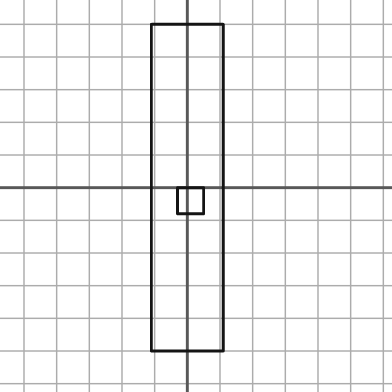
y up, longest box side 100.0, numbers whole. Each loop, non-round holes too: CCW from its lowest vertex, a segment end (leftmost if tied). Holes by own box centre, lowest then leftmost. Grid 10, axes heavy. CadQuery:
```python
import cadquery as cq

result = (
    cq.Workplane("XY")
    .moveTo(-11.0, -50.0)
    .lineTo(11.0, -50.0)
    .lineTo(11.0, 50.0)
    .lineTo(-11.0, 50.0)
    .close()
    .moveTo(-3.0, -8.0)
    .lineTo(5.0, -8.0)
    .lineTo(5.0, 0.0)
    .lineTo(-3.0, 0.0)
    .close()
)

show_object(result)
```